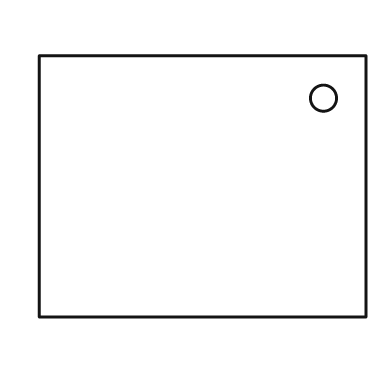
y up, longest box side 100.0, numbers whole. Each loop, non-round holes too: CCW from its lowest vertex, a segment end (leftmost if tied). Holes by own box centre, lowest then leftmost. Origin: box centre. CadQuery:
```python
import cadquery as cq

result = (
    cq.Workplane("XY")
    .moveTo(-50.0, -40.0)
    .lineTo(50.0, -40.0)
    .lineTo(50.0, 40.0)
    .lineTo(-50.0, 40.0)
    .close()
    .moveTo(37.0, 27.0)
    .circle(4.0)
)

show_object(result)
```